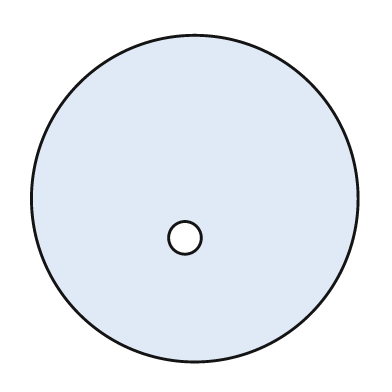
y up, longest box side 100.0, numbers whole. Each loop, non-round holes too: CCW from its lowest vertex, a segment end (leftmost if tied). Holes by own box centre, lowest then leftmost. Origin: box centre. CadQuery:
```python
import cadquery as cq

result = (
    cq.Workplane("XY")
    .moveTo(0.0, 0.0)
    .circle(50.0)
    .moveTo(-3.0, -12.0)
    .circle(5.0)
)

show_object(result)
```